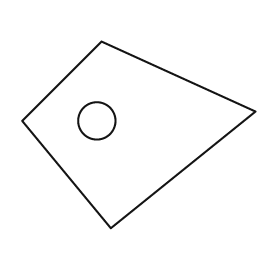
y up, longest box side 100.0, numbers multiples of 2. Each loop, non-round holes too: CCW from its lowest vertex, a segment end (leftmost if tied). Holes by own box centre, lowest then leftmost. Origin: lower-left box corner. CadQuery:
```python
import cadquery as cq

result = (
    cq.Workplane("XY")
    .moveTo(38.0, 0.0)
    .lineTo(100.0, 50.0)
    .lineTo(34.0, 80.0)
    .lineTo(0.0, 46.0)
    .close()
    .moveTo(32.0, 46.0)
    .circle(8.0)
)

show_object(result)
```